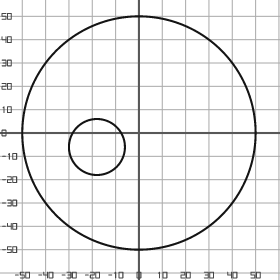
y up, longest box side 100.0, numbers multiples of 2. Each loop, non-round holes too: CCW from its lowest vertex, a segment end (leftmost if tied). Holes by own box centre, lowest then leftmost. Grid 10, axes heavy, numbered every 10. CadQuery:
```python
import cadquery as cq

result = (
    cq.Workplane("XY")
    .moveTo(0.0, 0.0)
    .circle(50.0)
    .moveTo(-18.0, -6.0)
    .circle(12.0)
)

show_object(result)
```